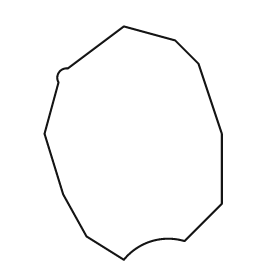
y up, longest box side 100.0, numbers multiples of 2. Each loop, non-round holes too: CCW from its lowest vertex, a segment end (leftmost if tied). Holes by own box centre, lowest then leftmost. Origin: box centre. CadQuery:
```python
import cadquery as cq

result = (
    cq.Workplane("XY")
    .moveTo(-4.0, -50.0)
    .threePointArc((8.0, -42.0), (22.0, -42.0))
    .lineTo(38.0, -26.0)
    .lineTo(38.0, 4.0)
    .lineTo(28.0, 34.0)
    .lineTo(18.0, 44.0)
    .lineTo(-4.0, 50.0)
    .lineTo(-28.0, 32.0)
    .threePointArc((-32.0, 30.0), (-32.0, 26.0))
    .lineTo(-38.0, 4.0)
    .lineTo(-30.0, -22.0)
    .lineTo(-20.0, -40.0)
    .close()
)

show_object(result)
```